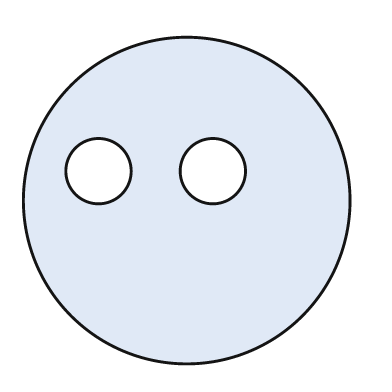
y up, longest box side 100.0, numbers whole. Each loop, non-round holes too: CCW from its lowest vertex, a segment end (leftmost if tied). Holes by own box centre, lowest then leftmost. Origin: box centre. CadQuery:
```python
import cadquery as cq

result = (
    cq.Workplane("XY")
    .moveTo(0.0, 0.0)
    .circle(50.0)
    .moveTo(-27.0, 9.0)
    .circle(10.0)
    .moveTo(8.0, 9.0)
    .circle(10.0)
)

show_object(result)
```